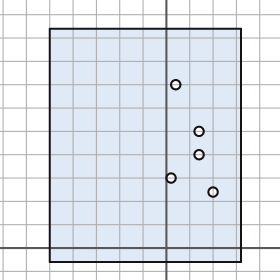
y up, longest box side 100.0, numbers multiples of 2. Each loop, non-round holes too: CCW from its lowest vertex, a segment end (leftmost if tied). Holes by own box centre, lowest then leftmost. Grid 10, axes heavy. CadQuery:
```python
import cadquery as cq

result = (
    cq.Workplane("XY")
    .moveTo(-50.0, -6.0)
    .lineTo(32.0, -6.0)
    .lineTo(32.0, 94.0)
    .lineTo(-50.0, 94.0)
    .close()
    .moveTo(20.0, 24.0)
    .circle(2.0)
    .moveTo(2.0, 30.0)
    .circle(2.0)
    .moveTo(14.0, 40.0)
    .circle(2.0)
    .moveTo(14.0, 50.0)
    .circle(2.0)
    .moveTo(4.0, 70.0)
    .circle(2.0)
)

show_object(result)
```